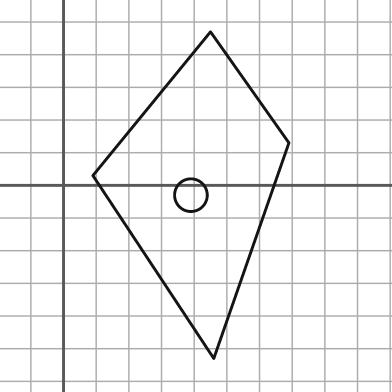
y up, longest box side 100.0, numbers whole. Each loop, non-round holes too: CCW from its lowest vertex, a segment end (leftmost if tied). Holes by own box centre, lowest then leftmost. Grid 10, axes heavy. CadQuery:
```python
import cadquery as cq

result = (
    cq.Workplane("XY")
    .moveTo(46.0, -53.0)
    .lineTo(69.0, 13.0)
    .lineTo(45.0, 47.0)
    .lineTo(9.0, 3.0)
    .close()
    .moveTo(39.0, -3.0)
    .circle(5.0)
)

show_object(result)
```